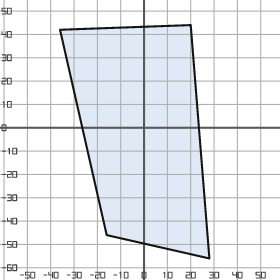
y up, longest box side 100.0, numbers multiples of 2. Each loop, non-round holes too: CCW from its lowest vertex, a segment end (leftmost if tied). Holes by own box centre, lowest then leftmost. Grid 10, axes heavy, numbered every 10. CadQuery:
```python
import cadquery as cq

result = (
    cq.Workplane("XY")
    .moveTo(28.0, -56.0)
    .lineTo(20.0, 44.0)
    .lineTo(-36.0, 42.0)
    .lineTo(-16.0, -46.0)
    .close()
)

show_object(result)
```